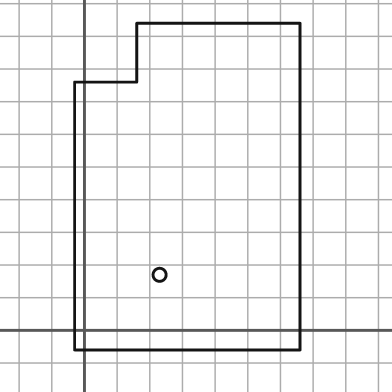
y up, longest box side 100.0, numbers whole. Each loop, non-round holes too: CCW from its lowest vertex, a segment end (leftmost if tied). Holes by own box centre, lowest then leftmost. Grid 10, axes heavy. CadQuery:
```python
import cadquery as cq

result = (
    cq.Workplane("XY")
    .moveTo(-3.0, -6.0)
    .lineTo(66.0, -6.0)
    .lineTo(66.0, 94.0)
    .lineTo(16.0, 94.0)
    .lineTo(16.0, 76.0)
    .lineTo(-3.0, 76.0)
    .close()
    .moveTo(23.0, 17.0)
    .circle(2.0)
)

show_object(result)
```